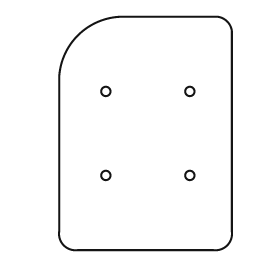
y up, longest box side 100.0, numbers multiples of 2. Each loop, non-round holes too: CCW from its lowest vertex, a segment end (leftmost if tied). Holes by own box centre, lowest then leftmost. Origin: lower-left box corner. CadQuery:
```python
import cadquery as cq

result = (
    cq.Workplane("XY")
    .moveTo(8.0, 0.0)
    .lineTo(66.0, 0.0)
    .threePointArc((72.0, 2.0), (74.0, 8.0))
    .lineTo(74.0, 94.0)
    .threePointArc((72.0, 98.0), (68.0, 100.0))
    .lineTo(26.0, 100.0)
    .threePointArc((8.0, 92.0), (0.0, 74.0))
    .lineTo(0.0, 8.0)
    .threePointArc((2.0, 2.0), (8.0, 0.0))
    .close()
    .moveTo(20.0, 32.0)
    .circle(2.0)
    .moveTo(56.0, 32.0)
    .circle(2.0)
    .moveTo(20.0, 68.0)
    .circle(2.0)
    .moveTo(56.0, 68.0)
    .circle(2.0)
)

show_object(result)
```